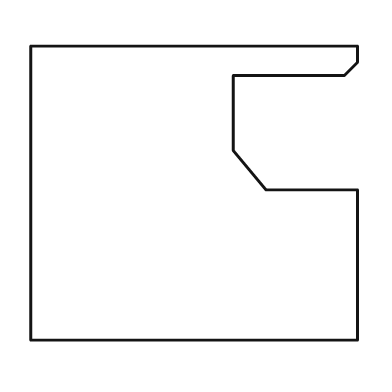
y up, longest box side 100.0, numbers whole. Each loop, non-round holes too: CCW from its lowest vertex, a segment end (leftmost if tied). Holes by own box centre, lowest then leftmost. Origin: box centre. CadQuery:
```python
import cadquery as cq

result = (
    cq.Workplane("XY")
    .moveTo(-50.0, -45.0)
    .lineTo(50.0, -45.0)
    .lineTo(50.0, 1.0)
    .lineTo(22.0, 1.0)
    .lineTo(12.0, 13.0)
    .lineTo(12.0, 36.0)
    .lineTo(46.0, 36.0)
    .lineTo(50.0, 40.0)
    .lineTo(50.0, 45.0)
    .lineTo(-50.0, 45.0)
    .close()
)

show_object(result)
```